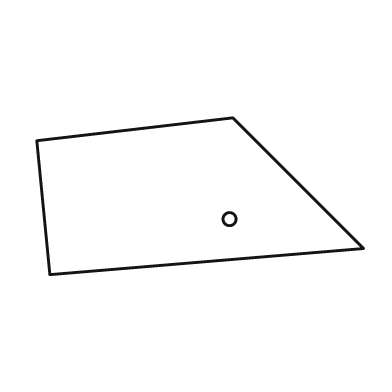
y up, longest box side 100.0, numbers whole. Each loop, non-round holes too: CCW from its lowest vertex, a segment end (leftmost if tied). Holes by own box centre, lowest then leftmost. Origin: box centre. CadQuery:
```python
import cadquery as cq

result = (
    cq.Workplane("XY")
    .moveTo(-46.0, -24.0)
    .lineTo(50.0, -16.0)
    .lineTo(10.0, 24.0)
    .lineTo(-50.0, 17.0)
    .close()
    .moveTo(9.0, -7.0)
    .circle(2.0)
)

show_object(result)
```